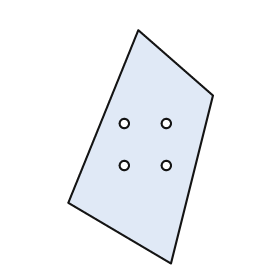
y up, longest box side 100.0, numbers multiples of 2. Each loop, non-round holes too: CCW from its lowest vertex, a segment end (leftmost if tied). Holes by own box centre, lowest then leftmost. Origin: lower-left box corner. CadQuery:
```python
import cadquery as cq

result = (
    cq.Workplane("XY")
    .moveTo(44.0, 0.0)
    .lineTo(62.0, 72.0)
    .lineTo(30.0, 100.0)
    .lineTo(0.0, 26.0)
    .close()
    .moveTo(24.0, 42.0)
    .circle(2.0)
    .moveTo(42.0, 42.0)
    .circle(2.0)
    .moveTo(24.0, 60.0)
    .circle(2.0)
    .moveTo(42.0, 60.0)
    .circle(2.0)
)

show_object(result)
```